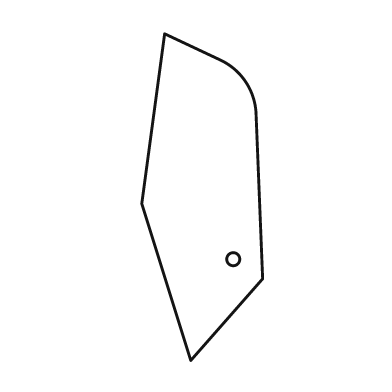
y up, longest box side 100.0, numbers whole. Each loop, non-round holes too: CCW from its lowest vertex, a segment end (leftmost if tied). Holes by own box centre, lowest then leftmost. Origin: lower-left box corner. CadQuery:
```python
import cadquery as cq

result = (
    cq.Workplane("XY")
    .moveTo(15.0, 0.0)
    .lineTo(37.0, 25.0)
    .lineTo(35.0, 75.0)
    .threePointArc((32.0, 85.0), (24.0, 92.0))
    .lineTo(7.0, 100.0)
    .lineTo(0.0, 48.0)
    .close()
    .moveTo(28.0, 31.0)
    .circle(2.0)
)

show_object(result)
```